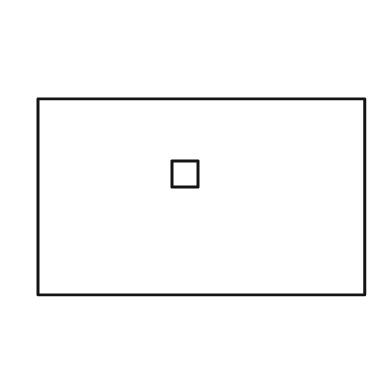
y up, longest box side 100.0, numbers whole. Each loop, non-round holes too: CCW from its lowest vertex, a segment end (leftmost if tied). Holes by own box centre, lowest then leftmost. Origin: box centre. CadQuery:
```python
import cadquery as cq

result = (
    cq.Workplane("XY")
    .moveTo(-50.0, -30.0)
    .lineTo(50.0, -30.0)
    .lineTo(50.0, 30.0)
    .lineTo(-50.0, 30.0)
    .close()
    .moveTo(-9.0, 3.0)
    .lineTo(-1.0, 3.0)
    .lineTo(-1.0, 11.0)
    .lineTo(-9.0, 11.0)
    .close()
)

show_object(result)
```